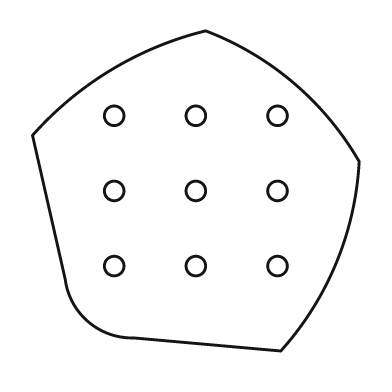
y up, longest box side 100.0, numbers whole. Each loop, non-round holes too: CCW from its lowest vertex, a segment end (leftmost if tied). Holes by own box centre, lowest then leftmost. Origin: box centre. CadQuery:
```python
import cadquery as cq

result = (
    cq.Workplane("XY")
    .moveTo(26.0, -49.0)
    .threePointArc((43.0, -22.0), (50.0, 9.0))
    .threePointArc((30.0, 33.0), (3.0, 49.0))
    .threePointArc((-26.0, 37.0), (-50.0, 17.0))
    .lineTo(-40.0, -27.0)
    .threePointArc((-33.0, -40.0), (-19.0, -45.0))
    .close()
    .moveTo(-25.0, -23.0)
    .circle(3.0)
    .moveTo(0.0, -23.0)
    .circle(3.0)
    .moveTo(25.0, -23.0)
    .circle(3.0)
    .moveTo(-25.0, 0.0)
    .circle(3.0)
    .moveTo(0.0, 0.0)
    .circle(3.0)
    .moveTo(25.0, 0.0)
    .circle(3.0)
    .moveTo(-25.0, 23.0)
    .circle(3.0)
    .moveTo(0.0, 23.0)
    .circle(3.0)
    .moveTo(25.0, 23.0)
    .circle(3.0)
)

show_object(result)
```